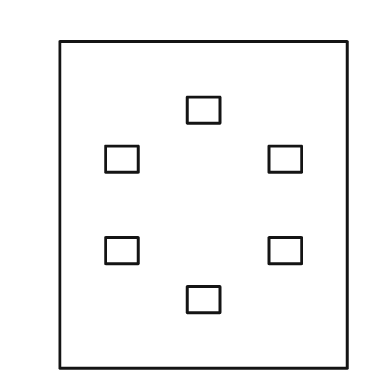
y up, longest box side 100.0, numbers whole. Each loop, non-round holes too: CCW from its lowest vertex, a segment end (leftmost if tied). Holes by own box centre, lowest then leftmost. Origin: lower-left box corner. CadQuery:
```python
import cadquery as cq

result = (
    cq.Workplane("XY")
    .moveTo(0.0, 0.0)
    .lineTo(88.0, 0.0)
    .lineTo(88.0, 100.0)
    .lineTo(0.0, 100.0)
    .close()
    .moveTo(39.0, 17.0)
    .lineTo(49.0, 17.0)
    .lineTo(49.0, 25.0)
    .lineTo(39.0, 25.0)
    .close()
    .moveTo(14.0, 32.0)
    .lineTo(24.0, 32.0)
    .lineTo(24.0, 40.0)
    .lineTo(14.0, 40.0)
    .close()
    .moveTo(64.0, 32.0)
    .lineTo(74.0, 32.0)
    .lineTo(74.0, 40.0)
    .lineTo(64.0, 40.0)
    .close()
    .moveTo(14.0, 60.0)
    .lineTo(24.0, 60.0)
    .lineTo(24.0, 68.0)
    .lineTo(14.0, 68.0)
    .close()
    .moveTo(64.0, 60.0)
    .lineTo(74.0, 60.0)
    .lineTo(74.0, 68.0)
    .lineTo(64.0, 68.0)
    .close()
    .moveTo(39.0, 75.0)
    .lineTo(49.0, 75.0)
    .lineTo(49.0, 83.0)
    .lineTo(39.0, 83.0)
    .close()
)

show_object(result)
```